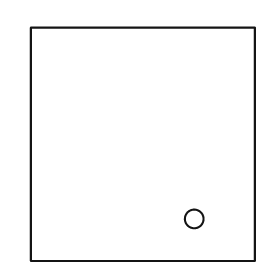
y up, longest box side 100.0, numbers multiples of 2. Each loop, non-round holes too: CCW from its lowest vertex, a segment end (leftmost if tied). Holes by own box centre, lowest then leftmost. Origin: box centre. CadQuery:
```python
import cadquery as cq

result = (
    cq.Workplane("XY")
    .moveTo(-48.0, -50.0)
    .lineTo(48.0, -50.0)
    .lineTo(48.0, 50.0)
    .lineTo(-48.0, 50.0)
    .close()
    .moveTo(22.0, -32.0)
    .circle(4.0)
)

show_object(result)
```